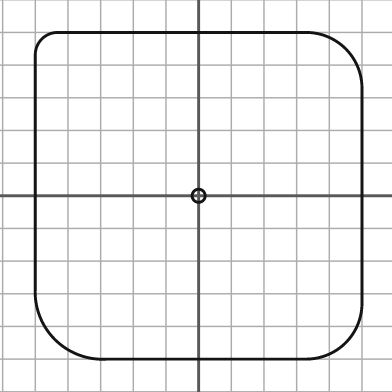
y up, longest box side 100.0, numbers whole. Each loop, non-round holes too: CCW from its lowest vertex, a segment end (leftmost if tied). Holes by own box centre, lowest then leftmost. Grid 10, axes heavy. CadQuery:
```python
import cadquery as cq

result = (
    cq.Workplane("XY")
    .moveTo(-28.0, -50.0)
    .lineTo(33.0, -50.0)
    .threePointArc((45.0, -45.0), (50.0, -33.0))
    .lineTo(50.0, 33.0)
    .threePointArc((45.0, 45.0), (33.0, 50.0))
    .lineTo(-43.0, 50.0)
    .threePointArc((-48.0, 48.0), (-50.0, 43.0))
    .lineTo(-50.0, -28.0)
    .threePointArc((-44.0, -44.0), (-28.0, -50.0))
    .close()
    .moveTo(0.0, 0.0)
    .circle(2.0)
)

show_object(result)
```